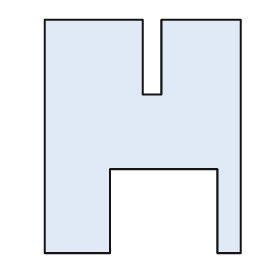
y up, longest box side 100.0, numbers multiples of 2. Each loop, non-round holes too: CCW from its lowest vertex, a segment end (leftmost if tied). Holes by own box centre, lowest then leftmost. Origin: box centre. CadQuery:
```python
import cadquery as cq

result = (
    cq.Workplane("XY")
    .moveTo(-42.0, -50.0)
    .lineTo(-14.0, -50.0)
    .lineTo(-14.0, -14.0)
    .lineTo(32.0, -14.0)
    .lineTo(32.0, -50.0)
    .lineTo(42.0, -50.0)
    .lineTo(42.0, 50.0)
    .lineTo(8.0, 50.0)
    .lineTo(8.0, 18.0)
    .lineTo(0.0, 18.0)
    .lineTo(0.0, 50.0)
    .lineTo(-42.0, 50.0)
    .close()
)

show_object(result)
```